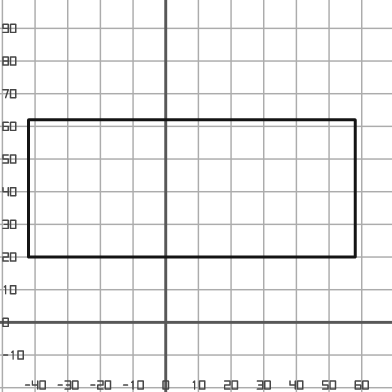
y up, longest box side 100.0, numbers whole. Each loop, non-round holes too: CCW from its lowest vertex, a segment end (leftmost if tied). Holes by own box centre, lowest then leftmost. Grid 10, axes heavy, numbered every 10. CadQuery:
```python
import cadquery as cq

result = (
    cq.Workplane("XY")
    .moveTo(-42.0, 20.0)
    .lineTo(58.0, 20.0)
    .lineTo(58.0, 62.0)
    .lineTo(-42.0, 62.0)
    .close()
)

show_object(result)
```